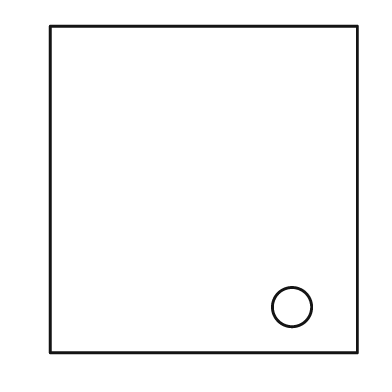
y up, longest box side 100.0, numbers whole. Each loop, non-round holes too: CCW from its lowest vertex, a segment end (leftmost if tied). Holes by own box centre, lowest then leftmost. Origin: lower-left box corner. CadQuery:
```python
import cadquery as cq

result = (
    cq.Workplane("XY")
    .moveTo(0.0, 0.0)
    .lineTo(94.0, 0.0)
    .lineTo(94.0, 100.0)
    .lineTo(0.0, 100.0)
    .close()
    .moveTo(74.0, 14.0)
    .circle(6.0)
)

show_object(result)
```